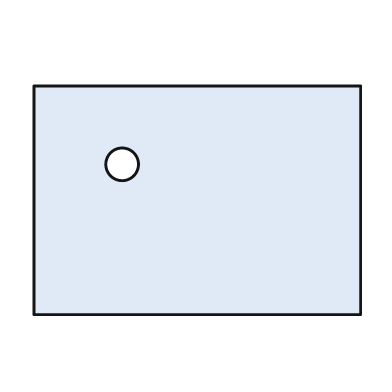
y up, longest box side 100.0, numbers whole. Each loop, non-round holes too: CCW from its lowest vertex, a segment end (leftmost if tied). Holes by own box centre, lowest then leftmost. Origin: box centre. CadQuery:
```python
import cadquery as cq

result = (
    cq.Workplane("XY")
    .moveTo(-50.0, -35.0)
    .lineTo(50.0, -35.0)
    .lineTo(50.0, 35.0)
    .lineTo(-50.0, 35.0)
    .close()
    .moveTo(-23.0, 11.0)
    .circle(5.0)
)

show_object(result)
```